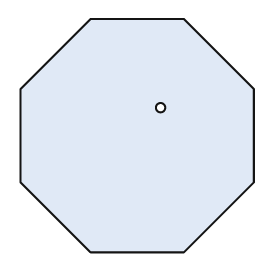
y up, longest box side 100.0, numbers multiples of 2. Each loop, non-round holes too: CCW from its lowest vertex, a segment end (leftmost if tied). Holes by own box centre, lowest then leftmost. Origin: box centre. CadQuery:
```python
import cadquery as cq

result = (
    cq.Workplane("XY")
    .moveTo(-20.0, -50.0)
    .lineTo(20.0, -50.0)
    .lineTo(50.0, -20.0)
    .lineTo(50.0, 20.0)
    .lineTo(20.0, 50.0)
    .lineTo(-20.0, 50.0)
    .lineTo(-50.0, 20.0)
    .lineTo(-50.0, -20.0)
    .close()
    .moveTo(10.0, 12.0)
    .circle(2.0)
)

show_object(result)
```